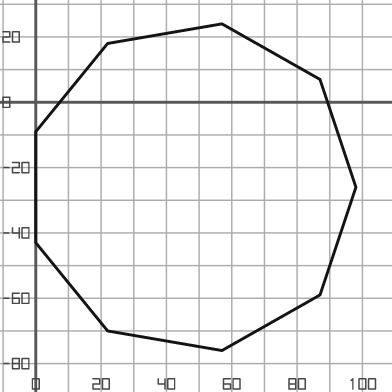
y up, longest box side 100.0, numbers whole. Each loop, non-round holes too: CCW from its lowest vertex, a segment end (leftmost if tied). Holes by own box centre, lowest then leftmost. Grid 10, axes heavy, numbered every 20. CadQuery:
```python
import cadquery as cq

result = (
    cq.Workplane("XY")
    .moveTo(57.0, -76.0)
    .lineTo(87.0, -59.0)
    .lineTo(98.0, -26.0)
    .lineTo(87.0, 7.0)
    .lineTo(57.0, 24.0)
    .lineTo(22.0, 18.0)
    .lineTo(0.0, -9.0)
    .lineTo(0.0, -43.0)
    .lineTo(22.0, -70.0)
    .close()
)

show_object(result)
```